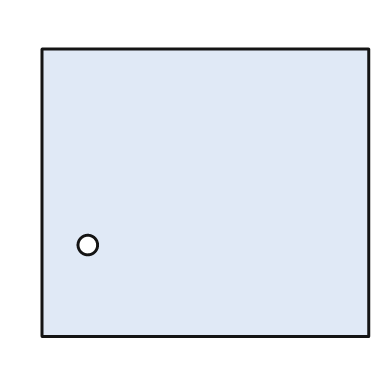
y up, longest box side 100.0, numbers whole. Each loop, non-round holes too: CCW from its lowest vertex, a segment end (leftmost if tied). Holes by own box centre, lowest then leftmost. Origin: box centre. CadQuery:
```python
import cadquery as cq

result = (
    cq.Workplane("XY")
    .moveTo(-50.0, -44.0)
    .lineTo(50.0, -44.0)
    .lineTo(50.0, 44.0)
    .lineTo(-50.0, 44.0)
    .close()
    .moveTo(-36.0, -16.0)
    .circle(3.0)
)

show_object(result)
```